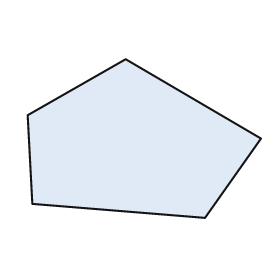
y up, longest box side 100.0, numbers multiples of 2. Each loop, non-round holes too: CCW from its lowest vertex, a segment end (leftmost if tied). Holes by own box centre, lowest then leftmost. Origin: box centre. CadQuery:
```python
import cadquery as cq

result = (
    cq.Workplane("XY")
    .moveTo(26.0, -34.0)
    .lineTo(50.0, 0.0)
    .lineTo(-8.0, 34.0)
    .lineTo(-50.0, 10.0)
    .lineTo(-48.0, -28.0)
    .close()
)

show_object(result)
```